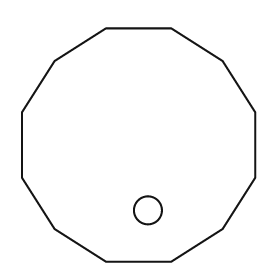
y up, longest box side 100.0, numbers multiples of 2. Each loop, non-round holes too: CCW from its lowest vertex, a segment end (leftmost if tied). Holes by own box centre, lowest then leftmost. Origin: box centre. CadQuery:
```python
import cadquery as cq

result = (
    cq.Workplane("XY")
    .moveTo(-14.0, -50.0)
    .lineTo(14.0, -50.0)
    .lineTo(36.0, -36.0)
    .lineTo(50.0, -14.0)
    .lineTo(50.0, 14.0)
    .lineTo(36.0, 36.0)
    .lineTo(14.0, 50.0)
    .lineTo(-14.0, 50.0)
    .lineTo(-36.0, 36.0)
    .lineTo(-50.0, 14.0)
    .lineTo(-50.0, -14.0)
    .lineTo(-36.0, -36.0)
    .close()
    .moveTo(4.0, -28.0)
    .circle(6.0)
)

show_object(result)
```